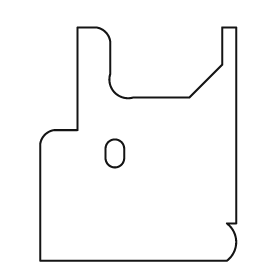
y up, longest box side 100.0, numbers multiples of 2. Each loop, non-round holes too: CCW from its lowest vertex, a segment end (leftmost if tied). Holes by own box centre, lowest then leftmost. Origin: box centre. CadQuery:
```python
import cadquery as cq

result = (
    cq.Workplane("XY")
    .moveTo(-42.0, -50.0)
    .lineTo(38.0, -50.0)
    .threePointArc((42.0, -42.0), (38.0, -34.0))
    .lineTo(42.0, -34.0)
    .lineTo(42.0, 50.0)
    .lineTo(36.0, 50.0)
    .lineTo(36.0, 34.0)
    .lineTo(22.0, 20.0)
    .lineTo(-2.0, 20.0)
    .threePointArc((-10.0, 22.0), (-12.0, 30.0))
    .lineTo(-12.0, 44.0)
    .threePointArc((-14.0, 48.0), (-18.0, 50.0))
    .lineTo(-26.0, 50.0)
    .lineTo(-26.0, 6.0)
    .lineTo(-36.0, 6.0)
    .threePointArc((-40.0, 4.0), (-42.0, 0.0))
    .close()
    .moveTo(-14.0, -6.0)
    .threePointArc((-10.0, -10.0), (-6.0, -6.0))
    .lineTo(-6.0, -2.0)
    .threePointArc((-10.0, 2.0), (-14.0, -2.0))
    .close()
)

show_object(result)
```